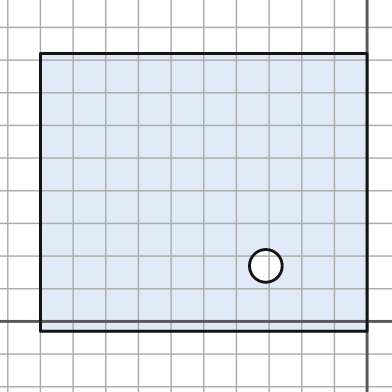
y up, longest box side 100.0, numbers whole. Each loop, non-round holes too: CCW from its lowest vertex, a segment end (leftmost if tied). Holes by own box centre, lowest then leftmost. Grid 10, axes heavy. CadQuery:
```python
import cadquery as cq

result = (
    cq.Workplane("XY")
    .moveTo(-100.0, -3.0)
    .lineTo(0.0, -3.0)
    .lineTo(0.0, 82.0)
    .lineTo(-100.0, 82.0)
    .close()
    .moveTo(-31.0, 17.0)
    .circle(5.0)
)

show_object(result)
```